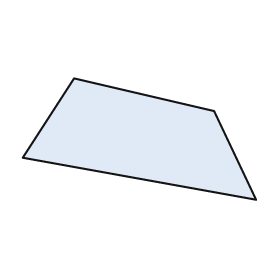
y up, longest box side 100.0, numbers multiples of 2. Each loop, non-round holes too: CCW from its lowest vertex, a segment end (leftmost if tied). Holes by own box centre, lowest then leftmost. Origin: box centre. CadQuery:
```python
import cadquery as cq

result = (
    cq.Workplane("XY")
    .moveTo(50.0, -26.0)
    .lineTo(32.0, 12.0)
    .lineTo(-28.0, 26.0)
    .lineTo(-50.0, -8.0)
    .close()
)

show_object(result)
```